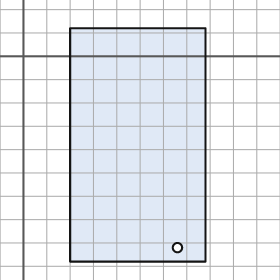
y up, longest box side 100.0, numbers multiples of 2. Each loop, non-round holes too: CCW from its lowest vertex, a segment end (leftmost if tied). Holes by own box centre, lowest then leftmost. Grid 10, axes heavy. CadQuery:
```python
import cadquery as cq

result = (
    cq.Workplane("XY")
    .moveTo(20.0, -88.0)
    .lineTo(78.0, -88.0)
    .lineTo(78.0, 12.0)
    .lineTo(20.0, 12.0)
    .close()
    .moveTo(66.0, -82.0)
    .circle(2.0)
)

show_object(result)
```